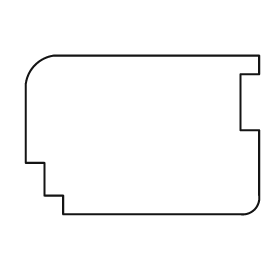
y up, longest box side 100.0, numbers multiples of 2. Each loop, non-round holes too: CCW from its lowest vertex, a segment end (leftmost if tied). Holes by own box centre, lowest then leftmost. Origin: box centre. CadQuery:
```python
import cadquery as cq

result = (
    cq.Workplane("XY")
    .moveTo(-34.0, -34.0)
    .lineTo(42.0, -34.0)
    .threePointArc((48.0, -32.0), (50.0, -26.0))
    .lineTo(50.0, 2.0)
    .lineTo(42.0, 2.0)
    .lineTo(42.0, 26.0)
    .lineTo(50.0, 26.0)
    .lineTo(50.0, 34.0)
    .lineTo(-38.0, 34.0)
    .threePointArc((-46.0, 30.0), (-50.0, 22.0))
    .lineTo(-50.0, -12.0)
    .lineTo(-42.0, -12.0)
    .lineTo(-42.0, -26.0)
    .lineTo(-34.0, -26.0)
    .close()
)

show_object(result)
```